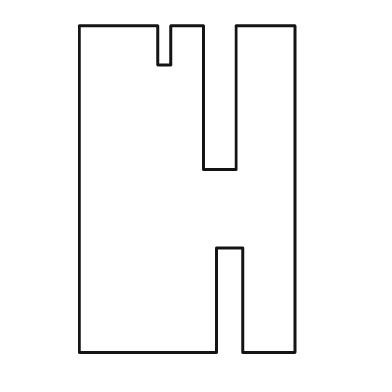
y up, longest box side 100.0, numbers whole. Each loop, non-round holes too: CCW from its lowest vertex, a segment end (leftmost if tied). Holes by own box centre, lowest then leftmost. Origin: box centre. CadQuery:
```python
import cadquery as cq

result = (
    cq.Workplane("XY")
    .moveTo(-33.0, -50.0)
    .lineTo(9.0, -50.0)
    .lineTo(9.0, -18.0)
    .lineTo(17.0, -18.0)
    .lineTo(17.0, -50.0)
    .lineTo(33.0, -50.0)
    .lineTo(33.0, 50.0)
    .lineTo(15.0, 50.0)
    .lineTo(15.0, 6.0)
    .lineTo(5.0, 6.0)
    .lineTo(5.0, 50.0)
    .lineTo(-5.0, 50.0)
    .lineTo(-5.0, 38.0)
    .lineTo(-9.0, 38.0)
    .lineTo(-9.0, 50.0)
    .lineTo(-33.0, 50.0)
    .close()
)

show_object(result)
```